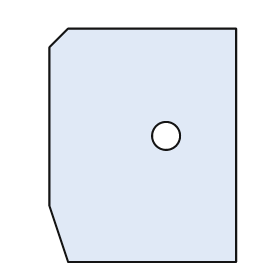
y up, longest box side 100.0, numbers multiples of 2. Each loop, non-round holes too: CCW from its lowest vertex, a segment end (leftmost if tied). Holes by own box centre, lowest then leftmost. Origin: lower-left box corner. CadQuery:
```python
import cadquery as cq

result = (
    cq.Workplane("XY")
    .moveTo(8.0, 0.0)
    .lineTo(80.0, 0.0)
    .lineTo(80.0, 100.0)
    .lineTo(8.0, 100.0)
    .lineTo(0.0, 92.0)
    .lineTo(0.0, 24.0)
    .close()
    .moveTo(50.0, 54.0)
    .circle(6.0)
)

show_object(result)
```